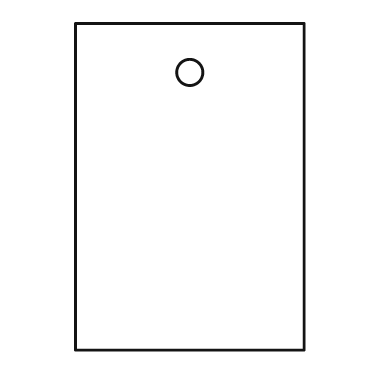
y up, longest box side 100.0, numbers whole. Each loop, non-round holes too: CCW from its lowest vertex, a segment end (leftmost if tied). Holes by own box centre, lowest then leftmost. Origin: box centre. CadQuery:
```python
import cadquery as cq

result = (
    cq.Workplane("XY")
    .moveTo(-35.0, -50.0)
    .lineTo(35.0, -50.0)
    .lineTo(35.0, 50.0)
    .lineTo(-35.0, 50.0)
    .close()
    .moveTo(0.0, 35.0)
    .circle(4.0)
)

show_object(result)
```